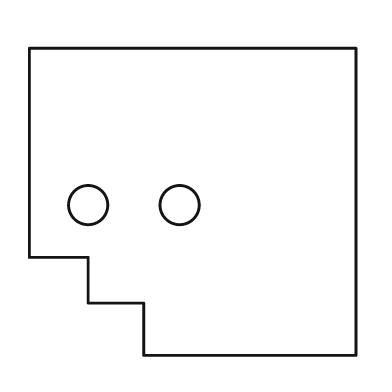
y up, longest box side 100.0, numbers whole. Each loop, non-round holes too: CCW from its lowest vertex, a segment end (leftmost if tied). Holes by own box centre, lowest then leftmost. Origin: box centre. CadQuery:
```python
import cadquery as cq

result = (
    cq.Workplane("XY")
    .moveTo(-15.0, -47.0)
    .lineTo(50.0, -47.0)
    .lineTo(50.0, 47.0)
    .lineTo(-50.0, 47.0)
    .lineTo(-50.0, -17.0)
    .lineTo(-32.0, -17.0)
    .lineTo(-32.0, -31.0)
    .lineTo(-15.0, -31.0)
    .close()
    .moveTo(-32.0, -1.0)
    .circle(6.0)
    .moveTo(-4.0, -1.0)
    .circle(6.0)
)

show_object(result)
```